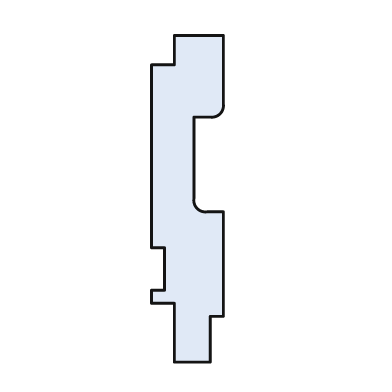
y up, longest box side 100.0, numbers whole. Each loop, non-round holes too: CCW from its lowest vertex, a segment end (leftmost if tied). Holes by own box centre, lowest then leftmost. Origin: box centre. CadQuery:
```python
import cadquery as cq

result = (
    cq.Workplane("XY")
    .moveTo(-4.0, -50.0)
    .lineTo(7.0, -50.0)
    .lineTo(7.0, -36.0)
    .lineTo(11.0, -36.0)
    .lineTo(11.0, -4.0)
    .lineTo(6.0, -4.0)
    .threePointArc((3.0, -3.0), (2.0, 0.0))
    .lineTo(2.0, 25.0)
    .lineTo(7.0, 25.0)
    .threePointArc((10.0, 26.0), (11.0, 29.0))
    .lineTo(11.0, 50.0)
    .lineTo(-4.0, 50.0)
    .lineTo(-4.0, 41.0)
    .lineTo(-11.0, 41.0)
    .lineTo(-11.0, -15.0)
    .lineTo(-7.0, -15.0)
    .lineTo(-7.0, -28.0)
    .lineTo(-11.0, -28.0)
    .lineTo(-11.0, -32.0)
    .lineTo(-4.0, -32.0)
    .close()
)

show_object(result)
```